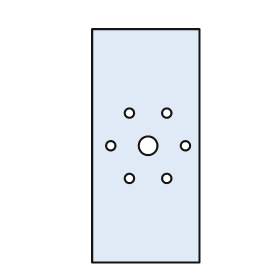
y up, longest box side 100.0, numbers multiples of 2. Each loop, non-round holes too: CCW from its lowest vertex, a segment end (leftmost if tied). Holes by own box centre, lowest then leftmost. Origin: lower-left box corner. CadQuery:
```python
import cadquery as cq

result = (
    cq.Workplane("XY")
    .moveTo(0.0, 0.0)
    .lineTo(46.0, 0.0)
    .lineTo(46.0, 100.0)
    .lineTo(0.0, 100.0)
    .close()
    .moveTo(16.0, 36.0)
    .circle(2.0)
    .moveTo(32.0, 36.0)
    .circle(2.0)
    .moveTo(8.0, 50.0)
    .circle(2.0)
    .moveTo(24.0, 50.0)
    .circle(4.0)
    .moveTo(40.0, 50.0)
    .circle(2.0)
    .moveTo(16.0, 64.0)
    .circle(2.0)
    .moveTo(32.0, 64.0)
    .circle(2.0)
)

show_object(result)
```